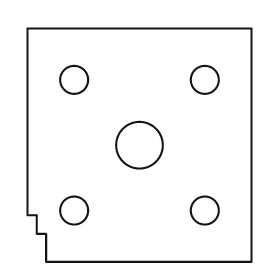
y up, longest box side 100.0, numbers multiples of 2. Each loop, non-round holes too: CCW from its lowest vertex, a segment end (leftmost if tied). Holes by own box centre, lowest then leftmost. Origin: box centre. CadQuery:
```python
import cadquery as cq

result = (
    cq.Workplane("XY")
    .moveTo(-40.0, -50.0)
    .lineTo(48.0, -50.0)
    .lineTo(48.0, 50.0)
    .lineTo(-48.0, 50.0)
    .lineTo(-48.0, -30.0)
    .lineTo(-44.0, -30.0)
    .lineTo(-44.0, -38.0)
    .lineTo(-40.0, -38.0)
    .close()
    .moveTo(-28.0, -28.0)
    .circle(6.0)
    .moveTo(28.0, -28.0)
    .circle(6.0)
    .moveTo(0.0, 0.0)
    .circle(10.0)
    .moveTo(-28.0, 28.0)
    .circle(6.0)
    .moveTo(28.0, 28.0)
    .circle(6.0)
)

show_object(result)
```